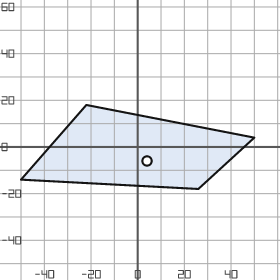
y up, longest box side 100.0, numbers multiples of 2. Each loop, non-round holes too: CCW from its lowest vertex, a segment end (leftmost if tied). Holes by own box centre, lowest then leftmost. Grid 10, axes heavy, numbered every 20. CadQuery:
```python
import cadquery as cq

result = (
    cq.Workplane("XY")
    .moveTo(26.0, -18.0)
    .lineTo(50.0, 4.0)
    .lineTo(-22.0, 18.0)
    .lineTo(-50.0, -14.0)
    .close()
    .moveTo(4.0, -6.0)
    .circle(2.0)
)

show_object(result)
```